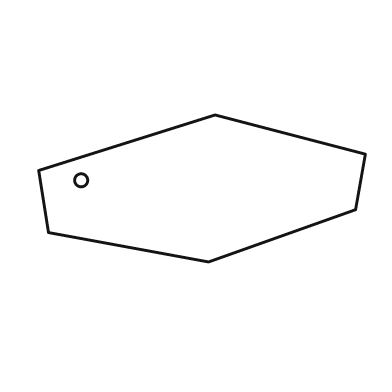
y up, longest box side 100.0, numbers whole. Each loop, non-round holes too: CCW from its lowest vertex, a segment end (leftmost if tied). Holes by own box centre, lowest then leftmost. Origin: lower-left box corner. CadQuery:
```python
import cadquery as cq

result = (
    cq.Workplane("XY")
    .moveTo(52.0, 0.0)
    .lineTo(97.0, 16.0)
    .lineTo(100.0, 33.0)
    .lineTo(54.0, 45.0)
    .lineTo(0.0, 28.0)
    .lineTo(3.0, 9.0)
    .close()
    .moveTo(13.0, 25.0)
    .circle(2.0)
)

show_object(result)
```